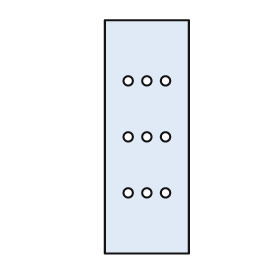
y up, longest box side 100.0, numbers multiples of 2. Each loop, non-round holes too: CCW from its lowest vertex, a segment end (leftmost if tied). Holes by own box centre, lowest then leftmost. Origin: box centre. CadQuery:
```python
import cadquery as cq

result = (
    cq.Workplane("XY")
    .moveTo(-18.0, -50.0)
    .lineTo(18.0, -50.0)
    .lineTo(18.0, 50.0)
    .lineTo(-18.0, 50.0)
    .close()
    .moveTo(-8.0, -24.0)
    .circle(2.0)
    .moveTo(0.0, -24.0)
    .circle(2.0)
    .moveTo(8.0, -24.0)
    .circle(2.0)
    .moveTo(-8.0, 0.0)
    .circle(2.0)
    .moveTo(0.0, 0.0)
    .circle(2.0)
    .moveTo(8.0, 0.0)
    .circle(2.0)
    .moveTo(-8.0, 24.0)
    .circle(2.0)
    .moveTo(0.0, 24.0)
    .circle(2.0)
    .moveTo(8.0, 24.0)
    .circle(2.0)
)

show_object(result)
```